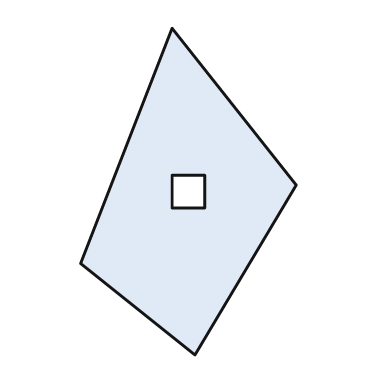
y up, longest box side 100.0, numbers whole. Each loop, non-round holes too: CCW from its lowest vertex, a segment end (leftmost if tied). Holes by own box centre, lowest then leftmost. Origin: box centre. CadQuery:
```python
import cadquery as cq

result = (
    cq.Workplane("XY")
    .moveTo(2.0, -50.0)
    .lineTo(33.0, 2.0)
    .lineTo(-5.0, 50.0)
    .lineTo(-33.0, -22.0)
    .close()
    .moveTo(-5.0, -5.0)
    .lineTo(5.0, -5.0)
    .lineTo(5.0, 5.0)
    .lineTo(-5.0, 5.0)
    .close()
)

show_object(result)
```